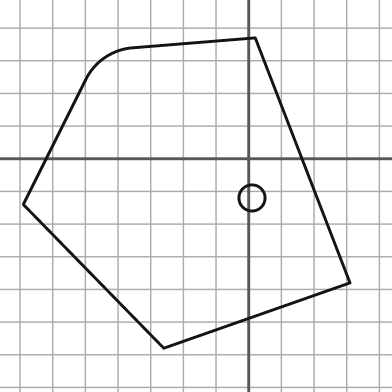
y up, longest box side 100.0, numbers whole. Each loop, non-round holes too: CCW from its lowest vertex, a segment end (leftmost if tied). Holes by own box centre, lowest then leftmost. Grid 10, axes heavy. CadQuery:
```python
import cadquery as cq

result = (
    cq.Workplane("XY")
    .moveTo(-26.0, -58.0)
    .lineTo(31.0, -38.0)
    .lineTo(2.0, 37.0)
    .lineTo(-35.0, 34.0)
    .threePointArc((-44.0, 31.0), (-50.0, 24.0))
    .lineTo(-69.0, -14.0)
    .close()
    .moveTo(1.0, -12.0)
    .circle(4.0)
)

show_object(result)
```